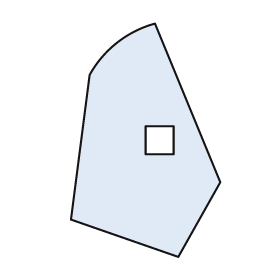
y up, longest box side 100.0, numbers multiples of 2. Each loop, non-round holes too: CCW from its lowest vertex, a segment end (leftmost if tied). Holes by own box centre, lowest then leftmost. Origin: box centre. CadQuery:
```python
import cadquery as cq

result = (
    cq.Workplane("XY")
    .moveTo(14.0, -50.0)
    .lineTo(32.0, -18.0)
    .lineTo(4.0, 50.0)
    .threePointArc((-12.0, 42.0), (-24.0, 28.0))
    .lineTo(-32.0, -34.0)
    .close()
    .moveTo(0.0, -6.0)
    .lineTo(12.0, -6.0)
    .lineTo(12.0, 6.0)
    .lineTo(0.0, 6.0)
    .close()
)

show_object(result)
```